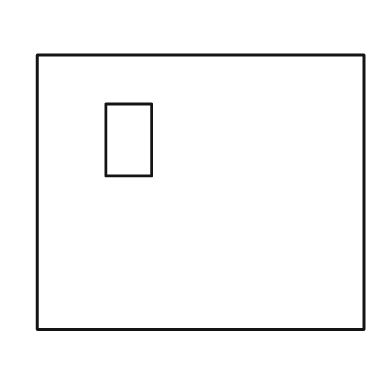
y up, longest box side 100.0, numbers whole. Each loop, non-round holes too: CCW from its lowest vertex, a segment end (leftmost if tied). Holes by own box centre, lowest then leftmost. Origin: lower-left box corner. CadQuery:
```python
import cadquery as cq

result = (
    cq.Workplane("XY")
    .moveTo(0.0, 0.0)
    .lineTo(100.0, 0.0)
    .lineTo(100.0, 84.0)
    .lineTo(0.0, 84.0)
    .close()
    .moveTo(21.0, 47.0)
    .lineTo(35.0, 47.0)
    .lineTo(35.0, 69.0)
    .lineTo(21.0, 69.0)
    .close()
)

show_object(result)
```